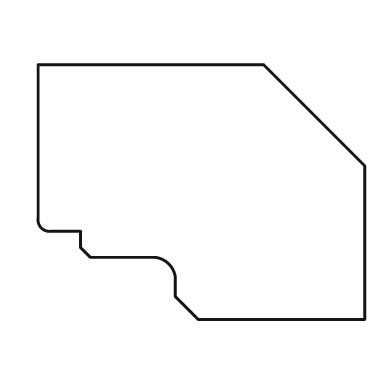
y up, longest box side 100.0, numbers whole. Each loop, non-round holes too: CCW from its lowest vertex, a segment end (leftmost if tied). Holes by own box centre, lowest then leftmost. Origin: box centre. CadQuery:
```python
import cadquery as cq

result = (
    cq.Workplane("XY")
    .moveTo(-1.0, -39.0)
    .lineTo(50.0, -39.0)
    .lineTo(50.0, 8.0)
    .lineTo(19.0, 39.0)
    .lineTo(-50.0, 39.0)
    .lineTo(-50.0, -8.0)
    .threePointArc((-49.0, -11.0), (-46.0, -12.0))
    .lineTo(-37.0, -12.0)
    .lineTo(-37.0, -17.0)
    .lineTo(-34.0, -20.0)
    .lineTo(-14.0, -20.0)
    .threePointArc((-10.0, -22.0), (-8.0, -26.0))
    .lineTo(-8.0, -32.0)
    .close()
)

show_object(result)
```